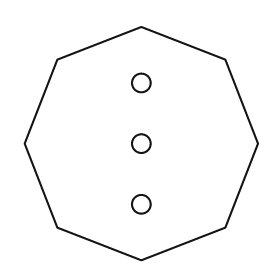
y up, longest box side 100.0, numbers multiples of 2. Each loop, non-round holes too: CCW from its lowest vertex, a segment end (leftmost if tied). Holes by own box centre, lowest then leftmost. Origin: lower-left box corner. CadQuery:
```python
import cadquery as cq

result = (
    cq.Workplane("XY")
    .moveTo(50.0, 0.0)
    .lineTo(86.0, 14.0)
    .lineTo(100.0, 50.0)
    .lineTo(86.0, 86.0)
    .lineTo(50.0, 100.0)
    .lineTo(14.0, 86.0)
    .lineTo(0.0, 50.0)
    .lineTo(14.0, 14.0)
    .close()
    .moveTo(50.0, 24.0)
    .circle(4.0)
    .moveTo(50.0, 50.0)
    .circle(4.0)
    .moveTo(50.0, 76.0)
    .circle(4.0)
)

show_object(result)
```